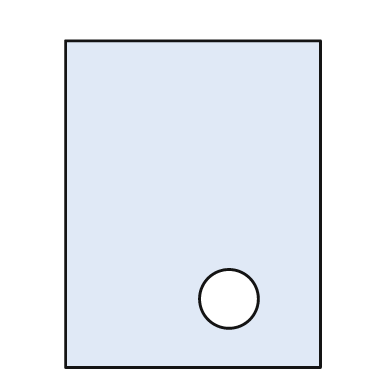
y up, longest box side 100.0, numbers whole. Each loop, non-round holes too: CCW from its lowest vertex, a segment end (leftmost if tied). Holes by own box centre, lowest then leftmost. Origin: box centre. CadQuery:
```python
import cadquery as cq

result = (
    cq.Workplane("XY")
    .moveTo(-39.0, -50.0)
    .lineTo(39.0, -50.0)
    .lineTo(39.0, 50.0)
    .lineTo(-39.0, 50.0)
    .close()
    .moveTo(11.0, -29.0)
    .circle(9.0)
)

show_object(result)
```